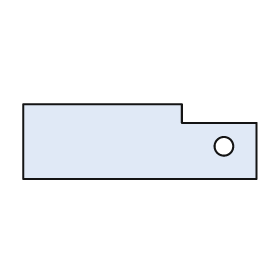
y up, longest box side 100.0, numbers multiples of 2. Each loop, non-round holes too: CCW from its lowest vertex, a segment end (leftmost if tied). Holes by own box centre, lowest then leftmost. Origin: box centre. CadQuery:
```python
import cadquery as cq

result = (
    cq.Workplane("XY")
    .moveTo(-50.0, -16.0)
    .lineTo(50.0, -16.0)
    .lineTo(50.0, 8.0)
    .lineTo(18.0, 8.0)
    .lineTo(18.0, 16.0)
    .lineTo(-50.0, 16.0)
    .close()
    .moveTo(36.0, -2.0)
    .circle(4.0)
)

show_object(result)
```